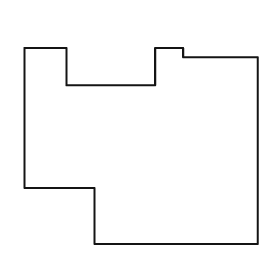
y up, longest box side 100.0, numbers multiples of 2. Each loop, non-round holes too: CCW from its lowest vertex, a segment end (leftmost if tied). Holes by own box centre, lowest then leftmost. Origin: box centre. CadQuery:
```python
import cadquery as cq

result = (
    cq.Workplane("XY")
    .moveTo(-20.0, -42.0)
    .lineTo(50.0, -42.0)
    .lineTo(50.0, 38.0)
    .lineTo(18.0, 38.0)
    .lineTo(18.0, 42.0)
    .lineTo(6.0, 42.0)
    .lineTo(6.0, 26.0)
    .lineTo(-32.0, 26.0)
    .lineTo(-32.0, 42.0)
    .lineTo(-50.0, 42.0)
    .lineTo(-50.0, -18.0)
    .lineTo(-20.0, -18.0)
    .close()
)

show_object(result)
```